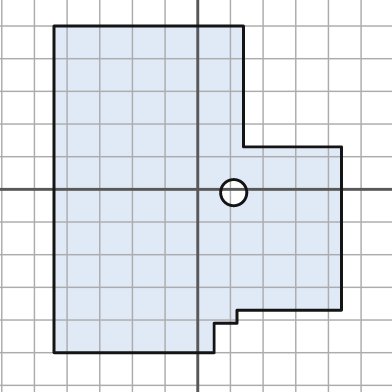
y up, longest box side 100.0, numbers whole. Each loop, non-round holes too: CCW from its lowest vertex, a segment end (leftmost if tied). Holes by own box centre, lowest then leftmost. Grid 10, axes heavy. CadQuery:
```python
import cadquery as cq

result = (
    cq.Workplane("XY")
    .moveTo(-44.0, -50.0)
    .lineTo(5.0, -50.0)
    .lineTo(5.0, -41.0)
    .lineTo(12.0, -41.0)
    .lineTo(12.0, -37.0)
    .lineTo(44.0, -37.0)
    .lineTo(44.0, 13.0)
    .lineTo(14.0, 13.0)
    .lineTo(14.0, 50.0)
    .lineTo(-44.0, 50.0)
    .close()
    .moveTo(11.0, -1.0)
    .circle(4.0)
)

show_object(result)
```